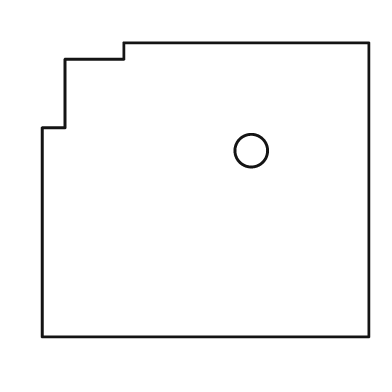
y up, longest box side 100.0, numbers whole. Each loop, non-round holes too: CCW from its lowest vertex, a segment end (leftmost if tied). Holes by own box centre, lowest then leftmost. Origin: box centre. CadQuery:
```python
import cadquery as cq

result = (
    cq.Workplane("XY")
    .moveTo(-50.0, -45.0)
    .lineTo(50.0, -45.0)
    .lineTo(50.0, 45.0)
    .lineTo(-25.0, 45.0)
    .lineTo(-25.0, 40.0)
    .lineTo(-43.0, 40.0)
    .lineTo(-43.0, 19.0)
    .lineTo(-50.0, 19.0)
    .close()
    .moveTo(14.0, 12.0)
    .circle(5.0)
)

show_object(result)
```